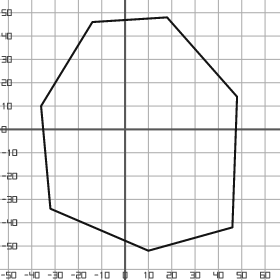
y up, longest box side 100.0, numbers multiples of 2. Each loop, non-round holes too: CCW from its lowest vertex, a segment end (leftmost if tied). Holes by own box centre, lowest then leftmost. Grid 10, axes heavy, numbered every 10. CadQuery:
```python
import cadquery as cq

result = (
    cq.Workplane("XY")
    .moveTo(10.0, -52.0)
    .lineTo(46.0, -42.0)
    .lineTo(48.0, 14.0)
    .lineTo(18.0, 48.0)
    .lineTo(-14.0, 46.0)
    .lineTo(-36.0, 10.0)
    .lineTo(-32.0, -34.0)
    .close()
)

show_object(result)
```